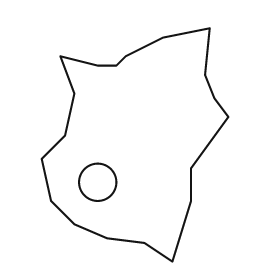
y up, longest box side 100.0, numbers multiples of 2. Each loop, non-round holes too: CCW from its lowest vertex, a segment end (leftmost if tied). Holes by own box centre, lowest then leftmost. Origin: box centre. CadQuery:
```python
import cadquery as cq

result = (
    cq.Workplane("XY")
    .moveTo(16.0, -50.0)
    .lineTo(24.0, -24.0)
    .lineTo(24.0, -10.0)
    .lineTo(40.0, 12.0)
    .lineTo(34.0, 20.0)
    .lineTo(30.0, 30.0)
    .lineTo(32.0, 50.0)
    .lineTo(12.0, 46.0)
    .lineTo(-4.0, 38.0)
    .lineTo(-8.0, 34.0)
    .lineTo(-16.0, 34.0)
    .lineTo(-32.0, 38.0)
    .lineTo(-26.0, 22.0)
    .lineTo(-30.0, 4.0)
    .lineTo(-40.0, -6.0)
    .lineTo(-36.0, -24.0)
    .lineTo(-26.0, -34.0)
    .lineTo(-12.0, -40.0)
    .lineTo(4.0, -42.0)
    .close()
    .moveTo(-16.0, -16.0)
    .circle(8.0)
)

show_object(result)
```